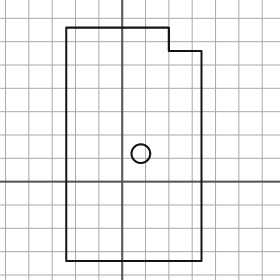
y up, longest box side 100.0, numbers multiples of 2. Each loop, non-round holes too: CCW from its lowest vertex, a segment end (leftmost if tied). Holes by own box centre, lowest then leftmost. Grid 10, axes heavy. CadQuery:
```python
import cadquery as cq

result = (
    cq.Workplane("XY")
    .moveTo(-24.0, -34.0)
    .lineTo(34.0, -34.0)
    .lineTo(34.0, 56.0)
    .lineTo(20.0, 56.0)
    .lineTo(20.0, 66.0)
    .lineTo(-24.0, 66.0)
    .close()
    .moveTo(8.0, 12.0)
    .circle(4.0)
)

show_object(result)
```